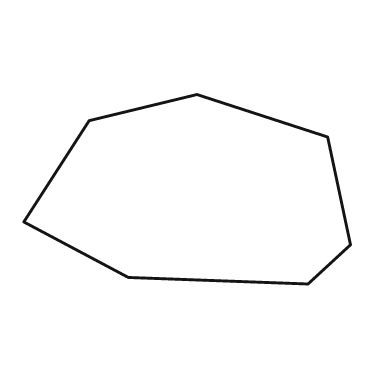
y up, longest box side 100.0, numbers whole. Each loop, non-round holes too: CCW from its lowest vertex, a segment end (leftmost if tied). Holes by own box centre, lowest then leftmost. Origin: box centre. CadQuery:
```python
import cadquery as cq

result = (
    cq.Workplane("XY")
    .moveTo(37.0, -29.0)
    .lineTo(50.0, -17.0)
    .lineTo(43.0, 16.0)
    .lineTo(3.0, 29.0)
    .lineTo(-30.0, 21.0)
    .lineTo(-50.0, -10.0)
    .lineTo(-18.0, -27.0)
    .close()
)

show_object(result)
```